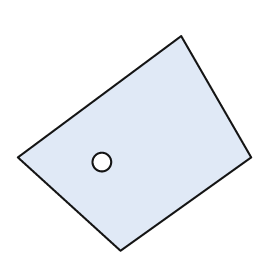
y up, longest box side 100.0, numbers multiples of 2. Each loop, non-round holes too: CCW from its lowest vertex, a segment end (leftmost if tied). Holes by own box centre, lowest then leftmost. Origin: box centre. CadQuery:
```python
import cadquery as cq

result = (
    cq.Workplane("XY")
    .moveTo(-6.0, -46.0)
    .lineTo(50.0, -6.0)
    .lineTo(20.0, 46.0)
    .lineTo(-50.0, -6.0)
    .close()
    .moveTo(-14.0, -8.0)
    .circle(4.0)
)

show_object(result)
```